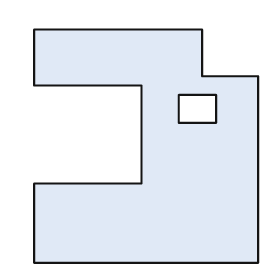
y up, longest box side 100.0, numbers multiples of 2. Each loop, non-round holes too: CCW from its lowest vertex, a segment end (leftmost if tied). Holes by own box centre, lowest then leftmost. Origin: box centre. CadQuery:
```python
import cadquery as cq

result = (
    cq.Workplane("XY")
    .moveTo(-48.0, -50.0)
    .lineTo(48.0, -50.0)
    .lineTo(48.0, 30.0)
    .lineTo(24.0, 30.0)
    .lineTo(24.0, 50.0)
    .lineTo(-48.0, 50.0)
    .lineTo(-48.0, 26.0)
    .lineTo(-2.0, 26.0)
    .lineTo(-2.0, -16.0)
    .lineTo(-48.0, -16.0)
    .close()
    .moveTo(14.0, 10.0)
    .lineTo(30.0, 10.0)
    .lineTo(30.0, 22.0)
    .lineTo(14.0, 22.0)
    .close()
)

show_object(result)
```